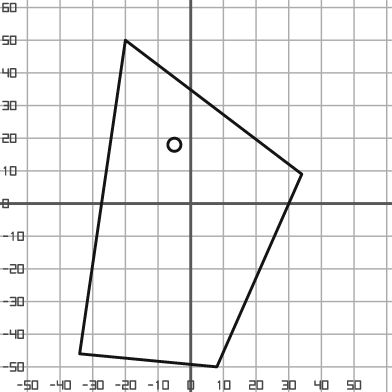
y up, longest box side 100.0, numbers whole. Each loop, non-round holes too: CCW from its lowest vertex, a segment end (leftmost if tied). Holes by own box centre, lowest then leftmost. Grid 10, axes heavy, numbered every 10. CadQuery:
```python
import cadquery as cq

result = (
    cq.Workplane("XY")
    .moveTo(8.0, -50.0)
    .lineTo(34.0, 9.0)
    .lineTo(-20.0, 50.0)
    .lineTo(-34.0, -46.0)
    .close()
    .moveTo(-5.0, 18.0)
    .circle(2.0)
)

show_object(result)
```